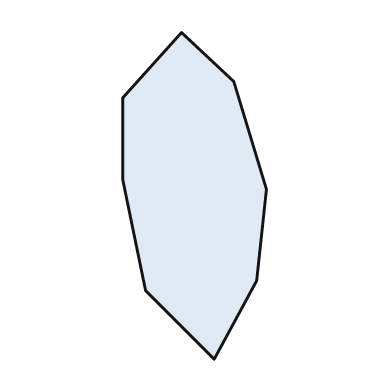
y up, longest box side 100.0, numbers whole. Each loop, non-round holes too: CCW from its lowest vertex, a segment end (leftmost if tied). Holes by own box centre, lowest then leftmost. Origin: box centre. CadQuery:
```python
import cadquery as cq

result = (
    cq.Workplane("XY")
    .moveTo(6.0, -50.0)
    .lineTo(19.0, -26.0)
    .lineTo(22.0, 2.0)
    .lineTo(12.0, 35.0)
    .lineTo(-4.0, 50.0)
    .lineTo(-22.0, 30.0)
    .lineTo(-22.0, 5.0)
    .lineTo(-15.0, -29.0)
    .close()
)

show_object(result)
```